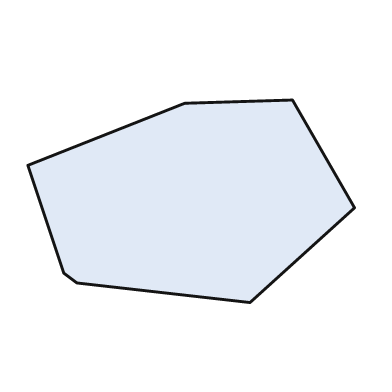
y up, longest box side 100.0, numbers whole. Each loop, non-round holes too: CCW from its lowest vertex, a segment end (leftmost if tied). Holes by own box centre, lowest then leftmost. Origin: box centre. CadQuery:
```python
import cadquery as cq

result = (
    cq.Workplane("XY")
    .moveTo(18.0, -31.0)
    .lineTo(50.0, -2.0)
    .lineTo(31.0, 31.0)
    .lineTo(-2.0, 30.0)
    .lineTo(-50.0, 11.0)
    .lineTo(-39.0, -22.0)
    .lineTo(-35.0, -25.0)
    .close()
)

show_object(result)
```